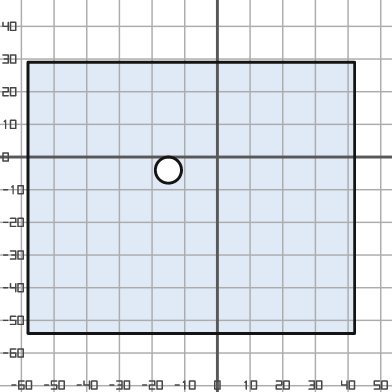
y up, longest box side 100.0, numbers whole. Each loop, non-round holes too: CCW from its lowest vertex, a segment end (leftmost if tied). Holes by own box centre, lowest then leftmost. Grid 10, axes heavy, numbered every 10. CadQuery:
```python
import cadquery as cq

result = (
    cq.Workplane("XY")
    .moveTo(-58.0, -54.0)
    .lineTo(42.0, -54.0)
    .lineTo(42.0, 29.0)
    .lineTo(-58.0, 29.0)
    .close()
    .moveTo(-15.0, -4.0)
    .circle(4.0)
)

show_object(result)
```